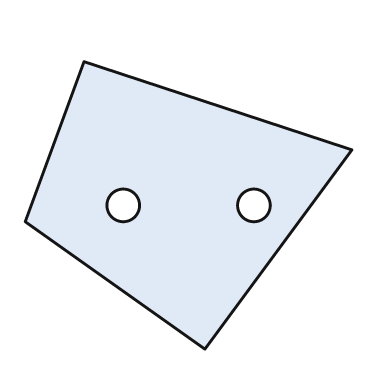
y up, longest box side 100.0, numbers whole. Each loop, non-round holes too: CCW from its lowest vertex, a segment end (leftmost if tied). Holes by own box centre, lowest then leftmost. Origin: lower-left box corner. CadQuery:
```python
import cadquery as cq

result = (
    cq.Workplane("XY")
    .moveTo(55.0, 0.0)
    .lineTo(100.0, 61.0)
    .lineTo(18.0, 88.0)
    .lineTo(0.0, 39.0)
    .close()
    .moveTo(30.0, 44.0)
    .circle(5.0)
    .moveTo(70.0, 44.0)
    .circle(5.0)
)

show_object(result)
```